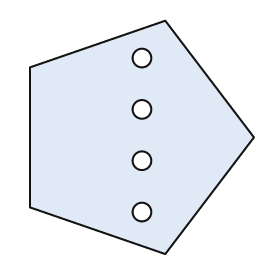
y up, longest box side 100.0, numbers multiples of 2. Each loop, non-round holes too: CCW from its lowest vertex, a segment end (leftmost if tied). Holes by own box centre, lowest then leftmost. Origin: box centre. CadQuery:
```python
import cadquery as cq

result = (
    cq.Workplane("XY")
    .moveTo(10.0, -50.0)
    .lineTo(48.0, 0.0)
    .lineTo(10.0, 50.0)
    .lineTo(-48.0, 30.0)
    .lineTo(-48.0, -30.0)
    .close()
    .moveTo(0.0, -32.0)
    .circle(4.0)
    .moveTo(0.0, -10.0)
    .circle(4.0)
    .moveTo(0.0, 12.0)
    .circle(4.0)
    .moveTo(0.0, 34.0)
    .circle(4.0)
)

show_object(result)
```